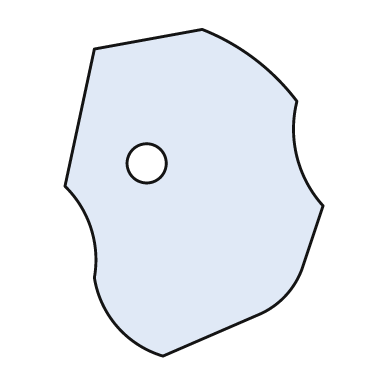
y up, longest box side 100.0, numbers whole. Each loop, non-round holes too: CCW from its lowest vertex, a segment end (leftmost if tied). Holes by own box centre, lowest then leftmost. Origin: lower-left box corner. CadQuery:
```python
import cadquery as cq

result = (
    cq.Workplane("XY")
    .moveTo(30.0, 0.0)
    .lineTo(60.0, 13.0)
    .threePointArc((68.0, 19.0), (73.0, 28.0))
    .lineTo(79.0, 46.0)
    .threePointArc((71.0, 61.0), (71.0, 78.0))
    .threePointArc((58.0, 91.0), (42.0, 100.0))
    .lineTo(9.0, 94.0)
    .lineTo(0.0, 52.0)
    .threePointArc((8.0, 39.0), (9.0, 24.0))
    .threePointArc((16.0, 9.0), (30.0, 0.0))
    .close()
    .moveTo(25.0, 59.0)
    .circle(6.0)
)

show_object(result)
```